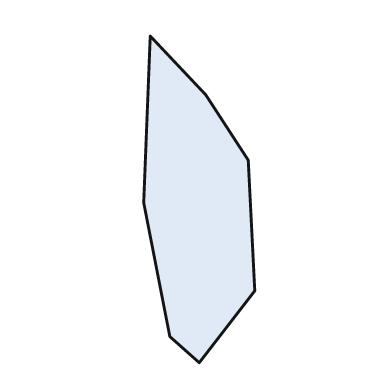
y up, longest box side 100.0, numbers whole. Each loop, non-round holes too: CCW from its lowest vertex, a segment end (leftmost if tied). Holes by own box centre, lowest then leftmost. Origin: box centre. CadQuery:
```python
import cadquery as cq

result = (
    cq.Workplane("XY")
    .moveTo(0.0, -50.0)
    .lineTo(17.0, -28.0)
    .lineTo(15.0, 12.0)
    .lineTo(2.0, 32.0)
    .lineTo(-15.0, 50.0)
    .lineTo(-17.0, -1.0)
    .lineTo(-9.0, -42.0)
    .close()
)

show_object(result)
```